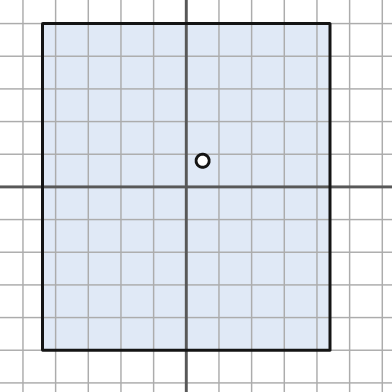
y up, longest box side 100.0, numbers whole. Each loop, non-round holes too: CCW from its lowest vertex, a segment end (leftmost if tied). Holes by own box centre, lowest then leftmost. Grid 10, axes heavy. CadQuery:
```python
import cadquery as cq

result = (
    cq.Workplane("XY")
    .moveTo(-44.0, -50.0)
    .lineTo(44.0, -50.0)
    .lineTo(44.0, 50.0)
    .lineTo(-44.0, 50.0)
    .close()
    .moveTo(5.0, 8.0)
    .circle(2.0)
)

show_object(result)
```